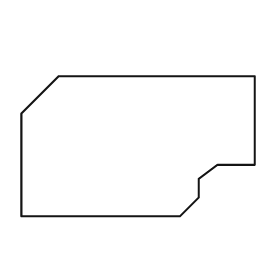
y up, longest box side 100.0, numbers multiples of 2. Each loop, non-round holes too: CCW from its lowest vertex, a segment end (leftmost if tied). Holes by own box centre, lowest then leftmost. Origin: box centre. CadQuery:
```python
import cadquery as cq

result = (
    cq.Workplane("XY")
    .moveTo(-50.0, -30.0)
    .lineTo(18.0, -30.0)
    .lineTo(26.0, -22.0)
    .lineTo(26.0, -14.0)
    .lineTo(34.0, -8.0)
    .lineTo(50.0, -8.0)
    .lineTo(50.0, 30.0)
    .lineTo(-34.0, 30.0)
    .lineTo(-50.0, 14.0)
    .close()
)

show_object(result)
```